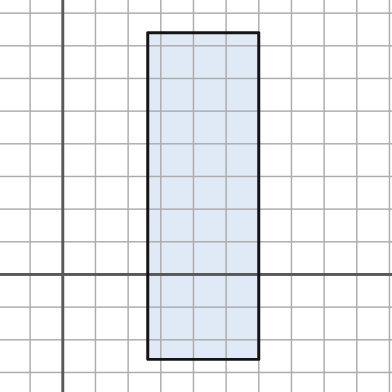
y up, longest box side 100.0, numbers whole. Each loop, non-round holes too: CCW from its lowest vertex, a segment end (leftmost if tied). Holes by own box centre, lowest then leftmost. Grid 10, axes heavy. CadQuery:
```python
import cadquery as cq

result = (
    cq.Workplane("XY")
    .moveTo(26.0, -26.0)
    .lineTo(60.0, -26.0)
    .lineTo(60.0, 74.0)
    .lineTo(26.0, 74.0)
    .close()
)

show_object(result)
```